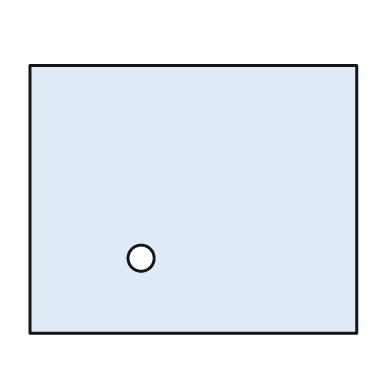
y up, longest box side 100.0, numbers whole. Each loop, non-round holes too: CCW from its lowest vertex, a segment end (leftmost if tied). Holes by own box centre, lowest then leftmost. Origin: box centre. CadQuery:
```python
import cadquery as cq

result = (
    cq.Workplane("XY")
    .moveTo(-50.0, -41.0)
    .lineTo(50.0, -41.0)
    .lineTo(50.0, 41.0)
    .lineTo(-50.0, 41.0)
    .close()
    .moveTo(-16.0, -18.0)
    .circle(4.0)
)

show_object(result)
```